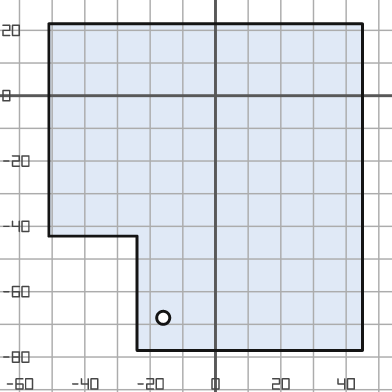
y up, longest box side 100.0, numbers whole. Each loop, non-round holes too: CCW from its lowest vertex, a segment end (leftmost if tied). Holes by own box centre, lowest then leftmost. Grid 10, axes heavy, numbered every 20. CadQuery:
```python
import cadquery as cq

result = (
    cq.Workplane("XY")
    .moveTo(-24.0, -78.0)
    .lineTo(45.0, -78.0)
    .lineTo(45.0, 22.0)
    .lineTo(-51.0, 22.0)
    .lineTo(-51.0, -43.0)
    .lineTo(-24.0, -43.0)
    .close()
    .moveTo(-16.0, -68.0)
    .circle(2.0)
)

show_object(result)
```